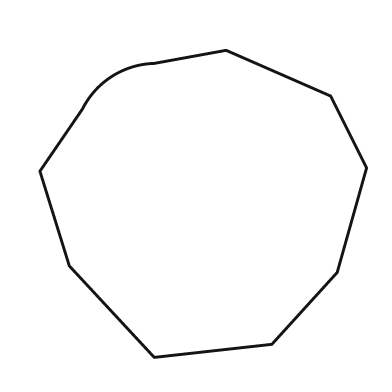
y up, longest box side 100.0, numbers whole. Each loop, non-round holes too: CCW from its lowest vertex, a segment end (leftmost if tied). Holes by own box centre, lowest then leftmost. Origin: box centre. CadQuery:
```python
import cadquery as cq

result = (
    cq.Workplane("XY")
    .moveTo(-15.0, -47.0)
    .lineTo(21.0, -43.0)
    .lineTo(41.0, -21.0)
    .lineTo(50.0, 11.0)
    .lineTo(39.0, 33.0)
    .lineTo(7.0, 47.0)
    .lineTo(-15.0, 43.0)
    .threePointArc((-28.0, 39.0), (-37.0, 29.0))
    .lineTo(-50.0, 10.0)
    .lineTo(-41.0, -19.0)
    .close()
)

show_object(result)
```